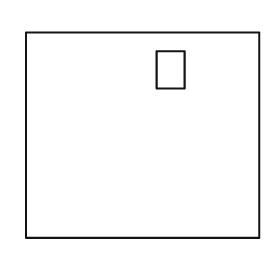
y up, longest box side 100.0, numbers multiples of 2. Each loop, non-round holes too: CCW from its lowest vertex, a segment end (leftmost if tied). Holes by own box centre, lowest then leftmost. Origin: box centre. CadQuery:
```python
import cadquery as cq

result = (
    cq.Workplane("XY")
    .moveTo(-50.0, -44.0)
    .lineTo(50.0, -44.0)
    .lineTo(50.0, 44.0)
    .lineTo(-50.0, 44.0)
    .close()
    .moveTo(6.0, 20.0)
    .lineTo(18.0, 20.0)
    .lineTo(18.0, 36.0)
    .lineTo(6.0, 36.0)
    .close()
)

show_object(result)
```